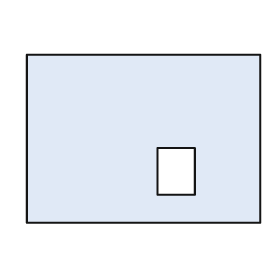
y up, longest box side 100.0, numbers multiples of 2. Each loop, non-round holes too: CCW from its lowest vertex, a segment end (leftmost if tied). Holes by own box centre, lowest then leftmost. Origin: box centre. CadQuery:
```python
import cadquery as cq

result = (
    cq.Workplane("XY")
    .moveTo(-50.0, -36.0)
    .lineTo(50.0, -36.0)
    .lineTo(50.0, 36.0)
    .lineTo(-50.0, 36.0)
    .close()
    .moveTo(6.0, -24.0)
    .lineTo(22.0, -24.0)
    .lineTo(22.0, -4.0)
    .lineTo(6.0, -4.0)
    .close()
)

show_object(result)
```